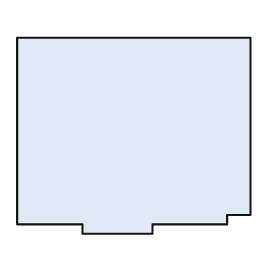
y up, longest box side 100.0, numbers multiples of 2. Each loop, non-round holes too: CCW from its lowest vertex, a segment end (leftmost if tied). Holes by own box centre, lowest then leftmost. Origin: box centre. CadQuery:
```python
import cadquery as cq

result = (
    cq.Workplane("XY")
    .moveTo(-22.0, -42.0)
    .lineTo(8.0, -42.0)
    .lineTo(8.0, -38.0)
    .lineTo(40.0, -38.0)
    .lineTo(40.0, -34.0)
    .lineTo(50.0, -34.0)
    .lineTo(50.0, 42.0)
    .lineTo(-50.0, 42.0)
    .lineTo(-50.0, -38.0)
    .lineTo(-22.0, -38.0)
    .close()
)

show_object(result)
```